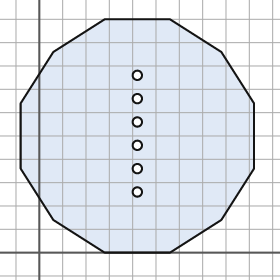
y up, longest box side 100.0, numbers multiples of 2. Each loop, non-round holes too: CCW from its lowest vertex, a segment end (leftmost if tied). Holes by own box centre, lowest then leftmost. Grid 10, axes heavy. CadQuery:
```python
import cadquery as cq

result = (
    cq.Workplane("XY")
    .moveTo(28.0, 0.0)
    .lineTo(56.0, 0.0)
    .lineTo(78.0, 14.0)
    .lineTo(92.0, 36.0)
    .lineTo(92.0, 64.0)
    .lineTo(78.0, 86.0)
    .lineTo(56.0, 100.0)
    .lineTo(28.0, 100.0)
    .lineTo(6.0, 86.0)
    .lineTo(-8.0, 64.0)
    .lineTo(-8.0, 36.0)
    .lineTo(6.0, 14.0)
    .close()
    .moveTo(42.0, 26.0)
    .circle(2.0)
    .moveTo(42.0, 36.0)
    .circle(2.0)
    .moveTo(42.0, 46.0)
    .circle(2.0)
    .moveTo(42.0, 56.0)
    .circle(2.0)
    .moveTo(42.0, 66.0)
    .circle(2.0)
    .moveTo(42.0, 76.0)
    .circle(2.0)
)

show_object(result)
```